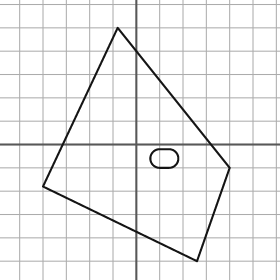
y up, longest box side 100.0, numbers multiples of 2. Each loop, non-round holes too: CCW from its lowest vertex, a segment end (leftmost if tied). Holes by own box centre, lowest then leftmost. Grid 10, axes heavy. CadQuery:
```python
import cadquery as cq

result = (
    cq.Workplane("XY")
    .moveTo(26.0, -50.0)
    .lineTo(40.0, -10.0)
    .lineTo(-8.0, 50.0)
    .lineTo(-40.0, -18.0)
    .close()
    .moveTo(10.0, -10.0)
    .lineTo(14.0, -10.0)
    .threePointArc((18.0, -6.0), (14.0, -2.0))
    .lineTo(10.0, -2.0)
    .threePointArc((6.0, -6.0), (10.0, -10.0))
    .close()
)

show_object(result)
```